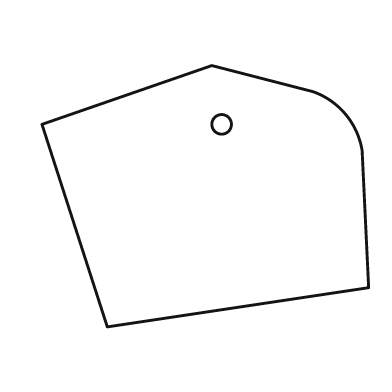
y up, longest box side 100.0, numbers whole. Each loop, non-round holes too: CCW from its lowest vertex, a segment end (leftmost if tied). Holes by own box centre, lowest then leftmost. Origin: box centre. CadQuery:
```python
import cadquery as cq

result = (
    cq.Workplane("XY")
    .moveTo(-30.0, -40.0)
    .lineTo(50.0, -28.0)
    .lineTo(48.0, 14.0)
    .threePointArc((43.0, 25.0), (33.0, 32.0))
    .lineTo(2.0, 40.0)
    .lineTo(-50.0, 22.0)
    .close()
    .moveTo(5.0, 22.0)
    .circle(3.0)
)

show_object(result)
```